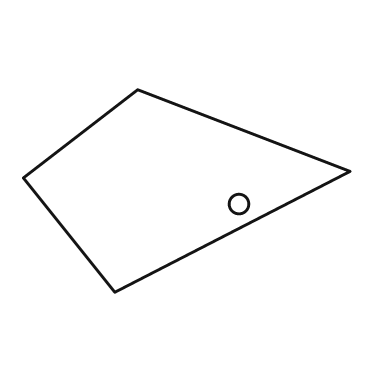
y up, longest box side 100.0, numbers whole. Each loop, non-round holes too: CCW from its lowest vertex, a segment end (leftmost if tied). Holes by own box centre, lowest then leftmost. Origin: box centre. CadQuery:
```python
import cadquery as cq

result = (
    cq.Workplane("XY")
    .moveTo(-22.0, -31.0)
    .lineTo(50.0, 6.0)
    .lineTo(-15.0, 31.0)
    .lineTo(-50.0, 4.0)
    .close()
    .moveTo(16.0, -4.0)
    .circle(3.0)
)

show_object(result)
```